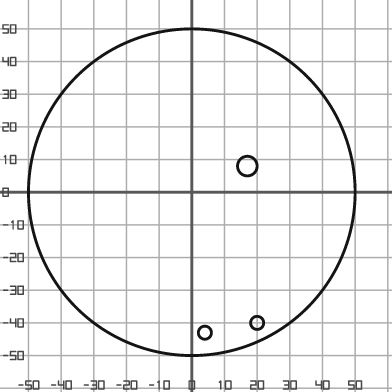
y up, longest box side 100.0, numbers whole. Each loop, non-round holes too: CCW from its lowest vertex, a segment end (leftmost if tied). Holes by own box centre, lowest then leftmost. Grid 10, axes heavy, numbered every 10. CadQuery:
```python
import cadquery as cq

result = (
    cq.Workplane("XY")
    .moveTo(0.0, 0.0)
    .circle(50.0)
    .moveTo(4.0, -43.0)
    .circle(2.0)
    .moveTo(20.0, -40.0)
    .circle(2.0)
    .moveTo(17.0, 8.0)
    .circle(3.0)
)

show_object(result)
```